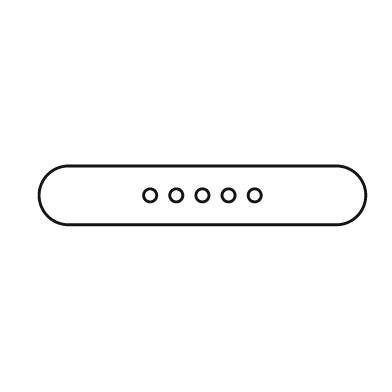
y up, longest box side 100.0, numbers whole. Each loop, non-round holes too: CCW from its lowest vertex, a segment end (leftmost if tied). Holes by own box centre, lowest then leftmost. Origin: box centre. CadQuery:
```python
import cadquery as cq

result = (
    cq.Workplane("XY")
    .moveTo(-41.0, -9.0)
    .lineTo(41.0, -9.0)
    .threePointArc((50.0, 0.0), (41.0, 9.0))
    .lineTo(-41.0, 9.0)
    .threePointArc((-50.0, 0.0), (-41.0, -9.0))
    .close()
    .moveTo(-16.0, 0.0)
    .circle(2.0)
    .moveTo(-8.0, 0.0)
    .circle(2.0)
    .moveTo(0.0, 0.0)
    .circle(2.0)
    .moveTo(8.0, 0.0)
    .circle(2.0)
    .moveTo(16.0, 0.0)
    .circle(2.0)
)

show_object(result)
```